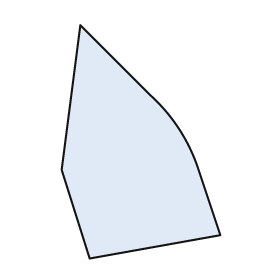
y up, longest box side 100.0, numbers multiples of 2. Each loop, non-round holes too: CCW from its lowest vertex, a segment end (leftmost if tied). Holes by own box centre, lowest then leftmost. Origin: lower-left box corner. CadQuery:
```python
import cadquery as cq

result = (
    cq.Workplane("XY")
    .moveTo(12.0, 0.0)
    .lineTo(68.0, 10.0)
    .lineTo(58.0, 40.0)
    .threePointArc((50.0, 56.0), (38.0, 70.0))
    .lineTo(8.0, 100.0)
    .lineTo(0.0, 38.0)
    .close()
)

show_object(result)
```